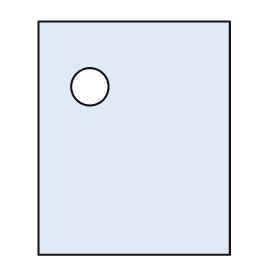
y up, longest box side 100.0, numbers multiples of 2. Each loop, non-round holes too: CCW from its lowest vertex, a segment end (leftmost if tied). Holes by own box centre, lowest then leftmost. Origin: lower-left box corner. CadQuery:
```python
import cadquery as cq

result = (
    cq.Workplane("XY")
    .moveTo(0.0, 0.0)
    .lineTo(82.0, 0.0)
    .lineTo(82.0, 100.0)
    .lineTo(0.0, 100.0)
    .close()
    .moveTo(22.0, 72.0)
    .circle(8.0)
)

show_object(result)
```